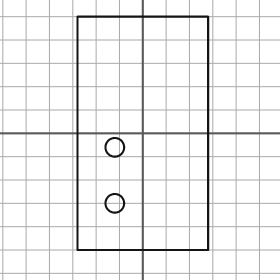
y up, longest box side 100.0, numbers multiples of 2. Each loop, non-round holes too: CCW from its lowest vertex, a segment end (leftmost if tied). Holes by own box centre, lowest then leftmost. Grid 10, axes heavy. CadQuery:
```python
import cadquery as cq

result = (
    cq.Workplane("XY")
    .moveTo(-28.0, -50.0)
    .lineTo(28.0, -50.0)
    .lineTo(28.0, 50.0)
    .lineTo(-28.0, 50.0)
    .close()
    .moveTo(-12.0, -30.0)
    .circle(4.0)
    .moveTo(-12.0, -6.0)
    .circle(4.0)
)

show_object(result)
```